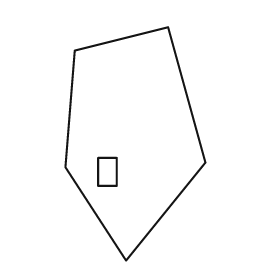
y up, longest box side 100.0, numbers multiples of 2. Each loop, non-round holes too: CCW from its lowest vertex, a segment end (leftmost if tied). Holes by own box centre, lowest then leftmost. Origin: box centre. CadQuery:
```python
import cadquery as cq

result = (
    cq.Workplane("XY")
    .moveTo(-4.0, -50.0)
    .lineTo(30.0, -8.0)
    .lineTo(14.0, 50.0)
    .lineTo(-26.0, 40.0)
    .lineTo(-30.0, -10.0)
    .close()
    .moveTo(-16.0, -18.0)
    .lineTo(-8.0, -18.0)
    .lineTo(-8.0, -6.0)
    .lineTo(-16.0, -6.0)
    .close()
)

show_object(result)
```